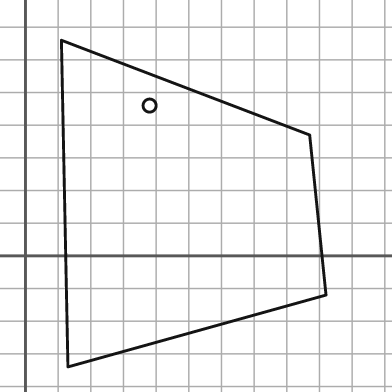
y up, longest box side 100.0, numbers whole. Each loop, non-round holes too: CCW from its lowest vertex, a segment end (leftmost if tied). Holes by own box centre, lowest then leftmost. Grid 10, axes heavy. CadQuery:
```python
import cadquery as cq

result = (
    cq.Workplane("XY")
    .moveTo(13.0, -34.0)
    .lineTo(92.0, -12.0)
    .lineTo(87.0, 37.0)
    .lineTo(11.0, 66.0)
    .close()
    .moveTo(38.0, 46.0)
    .circle(2.0)
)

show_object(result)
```